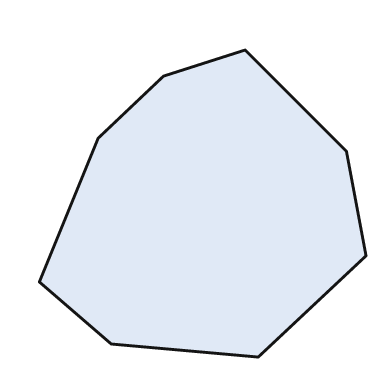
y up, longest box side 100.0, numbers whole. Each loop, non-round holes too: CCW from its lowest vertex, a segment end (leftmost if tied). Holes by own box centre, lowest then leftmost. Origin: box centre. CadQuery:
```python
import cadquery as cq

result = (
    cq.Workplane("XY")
    .moveTo(17.0, -47.0)
    .lineTo(50.0, -16.0)
    .lineTo(44.0, 16.0)
    .lineTo(13.0, 47.0)
    .lineTo(-12.0, 39.0)
    .lineTo(-32.0, 20.0)
    .lineTo(-50.0, -24.0)
    .lineTo(-28.0, -43.0)
    .close()
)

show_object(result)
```